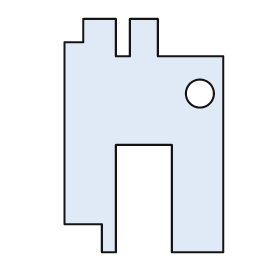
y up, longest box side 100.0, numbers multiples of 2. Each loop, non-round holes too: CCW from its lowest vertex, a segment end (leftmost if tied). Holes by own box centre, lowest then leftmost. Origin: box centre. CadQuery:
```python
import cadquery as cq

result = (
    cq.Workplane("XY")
    .moveTo(-18.0, -50.0)
    .lineTo(-12.0, -50.0)
    .lineTo(-12.0, -4.0)
    .lineTo(12.0, -4.0)
    .lineTo(12.0, -50.0)
    .lineTo(34.0, -50.0)
    .lineTo(34.0, 34.0)
    .lineTo(6.0, 34.0)
    .lineTo(6.0, 50.0)
    .lineTo(-6.0, 50.0)
    .lineTo(-6.0, 34.0)
    .lineTo(-12.0, 34.0)
    .lineTo(-12.0, 50.0)
    .lineTo(-26.0, 50.0)
    .lineTo(-26.0, 40.0)
    .lineTo(-34.0, 40.0)
    .lineTo(-34.0, -38.0)
    .lineTo(-18.0, -38.0)
    .close()
    .moveTo(24.0, 18.0)
    .circle(6.0)
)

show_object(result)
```